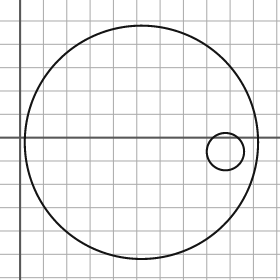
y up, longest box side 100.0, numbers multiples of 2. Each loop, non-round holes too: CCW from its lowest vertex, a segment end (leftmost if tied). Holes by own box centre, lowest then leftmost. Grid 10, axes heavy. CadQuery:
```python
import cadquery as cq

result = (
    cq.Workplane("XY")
    .moveTo(52.0, -2.0)
    .circle(50.0)
    .moveTo(88.0, -6.0)
    .circle(8.0)
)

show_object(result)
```